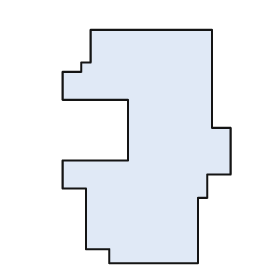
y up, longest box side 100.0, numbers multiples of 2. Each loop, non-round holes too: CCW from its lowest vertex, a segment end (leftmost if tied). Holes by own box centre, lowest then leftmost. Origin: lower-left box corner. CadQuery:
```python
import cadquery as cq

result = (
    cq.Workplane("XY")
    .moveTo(20.0, 0.0)
    .lineTo(58.0, 0.0)
    .lineTo(58.0, 28.0)
    .lineTo(62.0, 28.0)
    .lineTo(62.0, 38.0)
    .lineTo(72.0, 38.0)
    .lineTo(72.0, 58.0)
    .lineTo(64.0, 58.0)
    .lineTo(64.0, 100.0)
    .lineTo(12.0, 100.0)
    .lineTo(12.0, 86.0)
    .lineTo(8.0, 86.0)
    .lineTo(8.0, 82.0)
    .lineTo(0.0, 82.0)
    .lineTo(0.0, 70.0)
    .lineTo(28.0, 70.0)
    .lineTo(28.0, 44.0)
    .lineTo(0.0, 44.0)
    .lineTo(0.0, 32.0)
    .lineTo(10.0, 32.0)
    .lineTo(10.0, 6.0)
    .lineTo(20.0, 6.0)
    .close()
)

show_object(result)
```